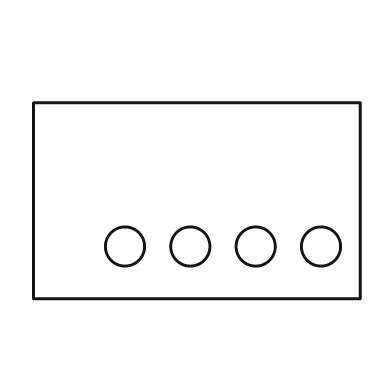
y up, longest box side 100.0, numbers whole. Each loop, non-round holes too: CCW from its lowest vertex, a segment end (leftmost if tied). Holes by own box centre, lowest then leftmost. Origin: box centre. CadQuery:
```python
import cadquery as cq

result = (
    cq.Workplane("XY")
    .moveTo(-50.0, -30.0)
    .lineTo(50.0, -30.0)
    .lineTo(50.0, 30.0)
    .lineTo(-50.0, 30.0)
    .close()
    .moveTo(-22.0, -14.0)
    .circle(6.0)
    .moveTo(-2.0, -14.0)
    .circle(6.0)
    .moveTo(18.0, -14.0)
    .circle(6.0)
    .moveTo(38.0, -14.0)
    .circle(6.0)
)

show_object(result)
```